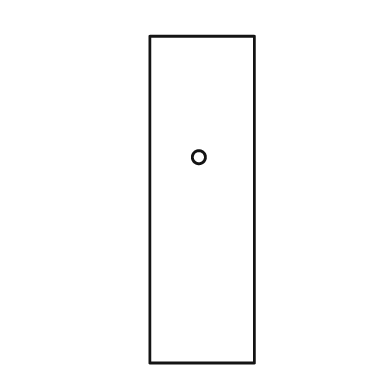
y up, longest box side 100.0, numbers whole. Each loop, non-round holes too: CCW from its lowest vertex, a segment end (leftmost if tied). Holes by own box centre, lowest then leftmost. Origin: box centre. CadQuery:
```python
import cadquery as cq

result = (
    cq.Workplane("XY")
    .moveTo(-16.0, -50.0)
    .lineTo(16.0, -50.0)
    .lineTo(16.0, 50.0)
    .lineTo(-16.0, 50.0)
    .close()
    .moveTo(-1.0, 13.0)
    .circle(2.0)
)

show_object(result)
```